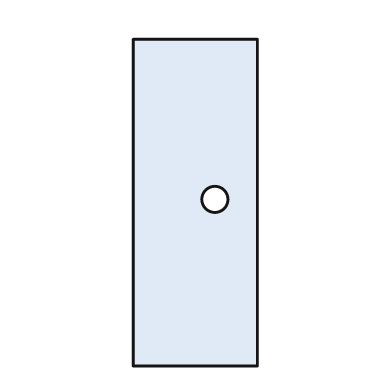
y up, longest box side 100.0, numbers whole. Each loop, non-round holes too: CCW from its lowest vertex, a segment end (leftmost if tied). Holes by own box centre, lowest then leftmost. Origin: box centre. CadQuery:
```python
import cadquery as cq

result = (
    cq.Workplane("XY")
    .moveTo(-19.0, -50.0)
    .lineTo(19.0, -50.0)
    .lineTo(19.0, 50.0)
    .lineTo(-19.0, 50.0)
    .close()
    .moveTo(6.0, 1.0)
    .circle(4.0)
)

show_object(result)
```